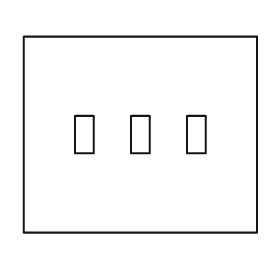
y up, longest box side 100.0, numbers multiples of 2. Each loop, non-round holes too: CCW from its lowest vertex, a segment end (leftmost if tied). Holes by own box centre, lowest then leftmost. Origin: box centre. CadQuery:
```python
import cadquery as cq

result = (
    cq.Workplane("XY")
    .moveTo(-50.0, -42.0)
    .lineTo(50.0, -42.0)
    .lineTo(50.0, 42.0)
    .lineTo(-50.0, 42.0)
    .close()
    .moveTo(-28.0, -8.0)
    .lineTo(-20.0, -8.0)
    .lineTo(-20.0, 8.0)
    .lineTo(-28.0, 8.0)
    .close()
    .moveTo(-4.0, -8.0)
    .lineTo(4.0, -8.0)
    .lineTo(4.0, 8.0)
    .lineTo(-4.0, 8.0)
    .close()
    .moveTo(20.0, -8.0)
    .lineTo(28.0, -8.0)
    .lineTo(28.0, 8.0)
    .lineTo(20.0, 8.0)
    .close()
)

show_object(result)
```